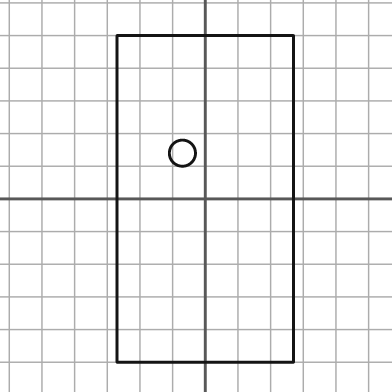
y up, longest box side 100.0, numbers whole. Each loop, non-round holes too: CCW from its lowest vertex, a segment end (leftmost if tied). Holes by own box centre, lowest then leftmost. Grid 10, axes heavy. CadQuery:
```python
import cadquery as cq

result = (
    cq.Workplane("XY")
    .moveTo(-27.0, -50.0)
    .lineTo(27.0, -50.0)
    .lineTo(27.0, 50.0)
    .lineTo(-27.0, 50.0)
    .close()
    .moveTo(-7.0, 14.0)
    .circle(4.0)
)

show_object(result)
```